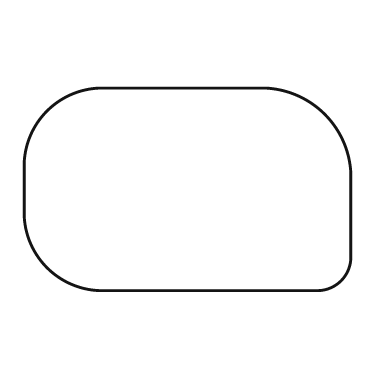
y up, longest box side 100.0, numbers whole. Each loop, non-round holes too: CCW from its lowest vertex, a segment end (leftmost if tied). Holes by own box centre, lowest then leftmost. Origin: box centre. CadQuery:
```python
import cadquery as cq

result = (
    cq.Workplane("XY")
    .moveTo(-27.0, -31.0)
    .lineTo(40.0, -31.0)
    .threePointArc((47.0, -28.0), (50.0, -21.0))
    .lineTo(50.0, 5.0)
    .threePointArc((42.0, 23.0), (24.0, 31.0))
    .lineTo(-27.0, 31.0)
    .threePointArc((-43.0, 24.0), (-50.0, 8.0))
    .lineTo(-50.0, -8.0)
    .threePointArc((-43.0, -24.0), (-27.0, -31.0))
    .close()
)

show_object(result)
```